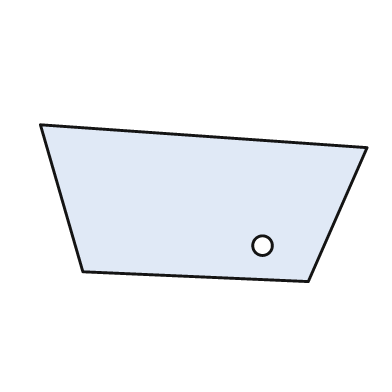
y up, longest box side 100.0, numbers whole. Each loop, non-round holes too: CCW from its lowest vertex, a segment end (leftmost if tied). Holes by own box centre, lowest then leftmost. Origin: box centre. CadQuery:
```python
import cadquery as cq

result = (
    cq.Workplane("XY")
    .moveTo(32.0, -24.0)
    .lineTo(50.0, 17.0)
    .lineTo(-50.0, 24.0)
    .lineTo(-37.0, -21.0)
    .close()
    .moveTo(18.0, -13.0)
    .circle(3.0)
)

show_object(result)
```